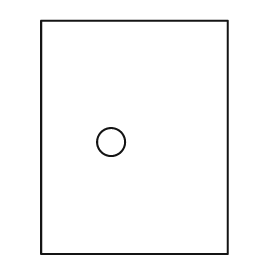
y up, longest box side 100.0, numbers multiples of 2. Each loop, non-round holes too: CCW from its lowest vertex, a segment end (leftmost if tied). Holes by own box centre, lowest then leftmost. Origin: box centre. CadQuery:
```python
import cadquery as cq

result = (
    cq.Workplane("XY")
    .moveTo(-40.0, -50.0)
    .lineTo(40.0, -50.0)
    .lineTo(40.0, 50.0)
    .lineTo(-40.0, 50.0)
    .close()
    .moveTo(-10.0, -2.0)
    .circle(6.0)
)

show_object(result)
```